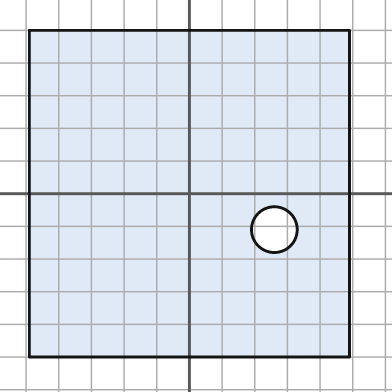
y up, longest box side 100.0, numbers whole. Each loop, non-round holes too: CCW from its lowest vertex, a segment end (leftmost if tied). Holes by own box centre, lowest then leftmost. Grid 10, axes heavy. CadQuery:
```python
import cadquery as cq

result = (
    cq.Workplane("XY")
    .moveTo(-49.0, -50.0)
    .lineTo(49.0, -50.0)
    .lineTo(49.0, 50.0)
    .lineTo(-49.0, 50.0)
    .close()
    .moveTo(26.0, -11.0)
    .circle(7.0)
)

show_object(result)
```